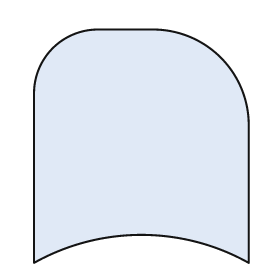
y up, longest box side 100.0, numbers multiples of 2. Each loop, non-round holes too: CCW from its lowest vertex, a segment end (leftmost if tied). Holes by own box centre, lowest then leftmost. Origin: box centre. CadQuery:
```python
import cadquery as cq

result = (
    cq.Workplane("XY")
    .moveTo(-46.0, -50.0)
    .threePointArc((0.0, -38.0), (46.0, -50.0))
    .lineTo(46.0, 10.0)
    .threePointArc((34.0, 38.0), (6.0, 50.0))
    .lineTo(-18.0, 50.0)
    .threePointArc((-38.0, 42.0), (-46.0, 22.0))
    .close()
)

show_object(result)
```